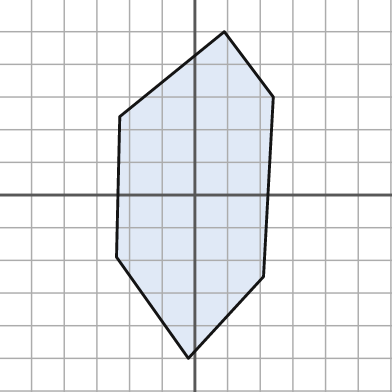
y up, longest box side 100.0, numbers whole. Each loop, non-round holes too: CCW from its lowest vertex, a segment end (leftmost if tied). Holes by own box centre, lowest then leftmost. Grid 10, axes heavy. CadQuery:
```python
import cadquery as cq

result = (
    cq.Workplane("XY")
    .moveTo(-2.0, -50.0)
    .lineTo(21.0, -25.0)
    .lineTo(24.0, 30.0)
    .lineTo(9.0, 50.0)
    .lineTo(-23.0, 24.0)
    .lineTo(-24.0, -19.0)
    .close()
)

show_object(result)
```